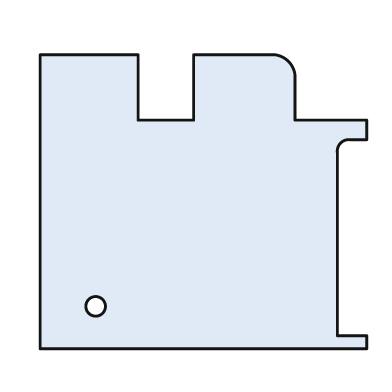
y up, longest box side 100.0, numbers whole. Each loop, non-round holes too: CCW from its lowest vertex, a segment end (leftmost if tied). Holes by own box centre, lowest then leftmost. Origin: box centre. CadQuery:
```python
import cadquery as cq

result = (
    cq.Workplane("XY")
    .moveTo(-50.0, -45.0)
    .lineTo(50.0, -45.0)
    .lineTo(50.0, -41.0)
    .lineTo(41.0, -41.0)
    .lineTo(41.0, 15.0)
    .threePointArc((42.0, 18.0), (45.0, 19.0))
    .lineTo(50.0, 19.0)
    .lineTo(50.0, 25.0)
    .lineTo(28.0, 25.0)
    .lineTo(28.0, 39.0)
    .threePointArc((26.0, 43.0), (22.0, 45.0))
    .lineTo(-3.0, 45.0)
    .lineTo(-3.0, 25.0)
    .lineTo(-20.0, 25.0)
    .lineTo(-20.0, 45.0)
    .lineTo(-50.0, 45.0)
    .close()
    .moveTo(-33.0, -32.0)
    .circle(3.0)
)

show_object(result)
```